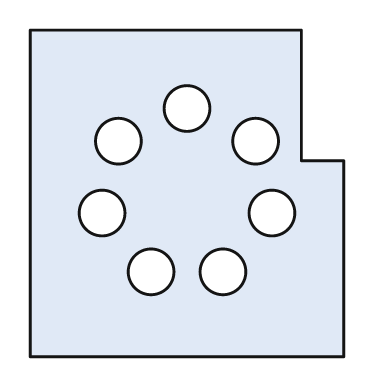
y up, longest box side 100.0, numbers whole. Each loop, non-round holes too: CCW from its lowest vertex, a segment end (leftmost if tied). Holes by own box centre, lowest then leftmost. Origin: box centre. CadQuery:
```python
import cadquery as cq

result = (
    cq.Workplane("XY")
    .moveTo(-48.0, -50.0)
    .lineTo(48.0, -50.0)
    .lineTo(48.0, 10.0)
    .lineTo(35.0, 10.0)
    .lineTo(35.0, 50.0)
    .lineTo(-48.0, 50.0)
    .close()
    .moveTo(-11.0, -24.0)
    .circle(7.0)
    .moveTo(11.0, -24.0)
    .circle(7.0)
    .moveTo(-26.0, -6.0)
    .circle(7.0)
    .moveTo(26.0, -6.0)
    .circle(7.0)
    .moveTo(-21.0, 16.0)
    .circle(7.0)
    .moveTo(21.0, 16.0)
    .circle(7.0)
    .moveTo(0.0, 26.0)
    .circle(7.0)
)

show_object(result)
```